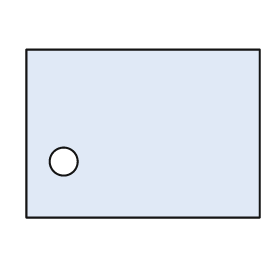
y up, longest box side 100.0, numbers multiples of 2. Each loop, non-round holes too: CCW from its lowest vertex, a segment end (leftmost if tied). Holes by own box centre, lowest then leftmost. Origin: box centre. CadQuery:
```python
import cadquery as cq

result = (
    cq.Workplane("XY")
    .moveTo(-50.0, -36.0)
    .lineTo(50.0, -36.0)
    .lineTo(50.0, 36.0)
    .lineTo(-50.0, 36.0)
    .close()
    .moveTo(-34.0, -12.0)
    .circle(6.0)
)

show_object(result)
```